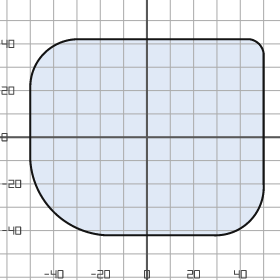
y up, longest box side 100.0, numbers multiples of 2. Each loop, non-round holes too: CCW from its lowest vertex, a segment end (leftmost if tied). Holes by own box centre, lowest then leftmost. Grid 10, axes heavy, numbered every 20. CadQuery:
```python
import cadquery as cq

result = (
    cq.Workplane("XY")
    .moveTo(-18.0, -42.0)
    .lineTo(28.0, -42.0)
    .threePointArc((44.0, -36.0), (50.0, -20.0))
    .lineTo(50.0, 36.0)
    .threePointArc((48.0, 40.0), (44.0, 42.0))
    .lineTo(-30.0, 42.0)
    .threePointArc((-44.0, 36.0), (-50.0, 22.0))
    .lineTo(-50.0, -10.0)
    .threePointArc((-40.0, -32.0), (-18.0, -42.0))
    .close()
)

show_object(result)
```